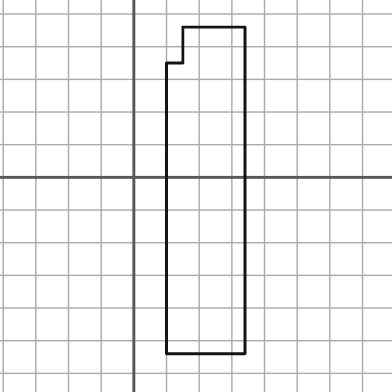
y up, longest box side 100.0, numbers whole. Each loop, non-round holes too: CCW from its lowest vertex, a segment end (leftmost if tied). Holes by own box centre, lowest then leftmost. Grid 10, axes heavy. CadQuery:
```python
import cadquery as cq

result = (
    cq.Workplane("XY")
    .moveTo(10.0, -54.0)
    .lineTo(34.0, -54.0)
    .lineTo(34.0, 46.0)
    .lineTo(15.0, 46.0)
    .lineTo(15.0, 35.0)
    .lineTo(10.0, 35.0)
    .close()
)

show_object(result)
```